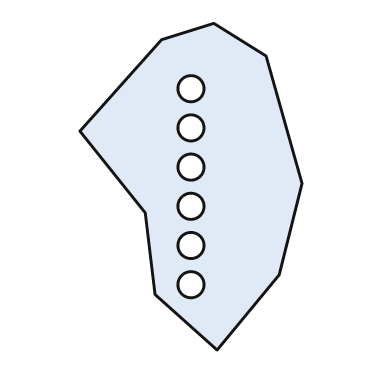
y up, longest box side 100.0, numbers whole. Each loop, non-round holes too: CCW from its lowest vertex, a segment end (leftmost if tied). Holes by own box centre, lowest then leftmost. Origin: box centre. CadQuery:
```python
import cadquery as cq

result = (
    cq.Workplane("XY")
    .moveTo(8.0, -50.0)
    .lineTo(27.0, -27.0)
    .lineTo(34.0, 1.0)
    .lineTo(23.0, 40.0)
    .lineTo(7.0, 50.0)
    .lineTo(-9.0, 45.0)
    .lineTo(-34.0, 17.0)
    .lineTo(-14.0, -8.0)
    .lineTo(-11.0, -33.0)
    .close()
    .moveTo(0.0, -30.0)
    .circle(4.0)
    .moveTo(0.0, -18.0)
    .circle(4.0)
    .moveTo(0.0, -6.0)
    .circle(4.0)
    .moveTo(0.0, 6.0)
    .circle(4.0)
    .moveTo(0.0, 18.0)
    .circle(4.0)
    .moveTo(0.0, 30.0)
    .circle(4.0)
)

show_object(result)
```